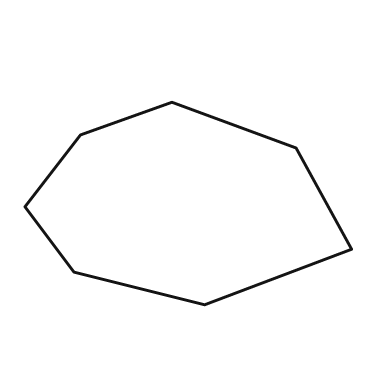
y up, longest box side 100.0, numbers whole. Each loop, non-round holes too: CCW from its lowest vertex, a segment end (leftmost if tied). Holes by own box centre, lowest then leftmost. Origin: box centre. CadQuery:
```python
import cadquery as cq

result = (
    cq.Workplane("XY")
    .moveTo(5.0, -31.0)
    .lineTo(50.0, -14.0)
    .lineTo(33.0, 17.0)
    .lineTo(-5.0, 31.0)
    .lineTo(-33.0, 21.0)
    .lineTo(-50.0, -1.0)
    .lineTo(-35.0, -21.0)
    .close()
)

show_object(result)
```